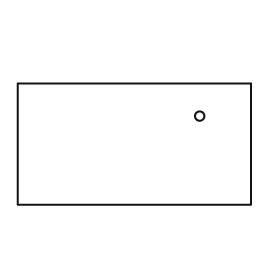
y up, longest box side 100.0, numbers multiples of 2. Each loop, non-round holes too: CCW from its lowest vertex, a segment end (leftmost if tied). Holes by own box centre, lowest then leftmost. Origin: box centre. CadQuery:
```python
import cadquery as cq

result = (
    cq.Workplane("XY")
    .moveTo(-50.0, -26.0)
    .lineTo(50.0, -26.0)
    .lineTo(50.0, 26.0)
    .lineTo(-50.0, 26.0)
    .close()
    .moveTo(28.0, 12.0)
    .circle(2.0)
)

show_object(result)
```